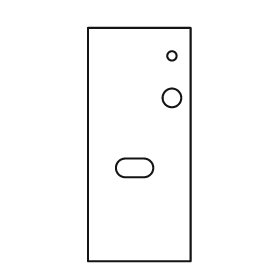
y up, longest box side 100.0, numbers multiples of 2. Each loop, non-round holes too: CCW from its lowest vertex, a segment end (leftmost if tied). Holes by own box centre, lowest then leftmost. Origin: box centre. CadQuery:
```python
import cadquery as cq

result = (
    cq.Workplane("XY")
    .moveTo(-22.0, -50.0)
    .lineTo(22.0, -50.0)
    .lineTo(22.0, 50.0)
    .lineTo(-22.0, 50.0)
    .close()
    .moveTo(-6.0, -14.0)
    .lineTo(2.0, -14.0)
    .threePointArc((6.0, -10.0), (2.0, -6.0))
    .lineTo(-6.0, -6.0)
    .threePointArc((-10.0, -10.0), (-6.0, -14.0))
    .close()
    .moveTo(14.0, 20.0)
    .circle(4.0)
    .moveTo(14.0, 38.0)
    .circle(2.0)
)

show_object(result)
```